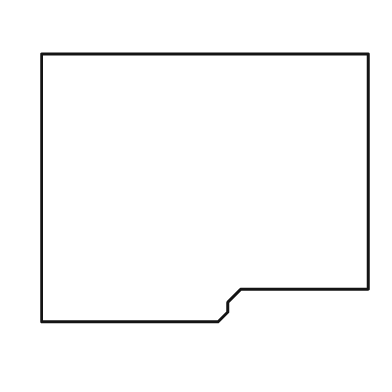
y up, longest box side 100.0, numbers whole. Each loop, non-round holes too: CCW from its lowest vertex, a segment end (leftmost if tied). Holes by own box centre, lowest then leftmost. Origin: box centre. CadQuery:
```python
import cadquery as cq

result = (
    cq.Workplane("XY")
    .moveTo(-50.0, -41.0)
    .lineTo(4.0, -41.0)
    .lineTo(7.0, -38.0)
    .lineTo(7.0, -35.0)
    .lineTo(11.0, -31.0)
    .lineTo(50.0, -31.0)
    .lineTo(50.0, 41.0)
    .lineTo(-50.0, 41.0)
    .close()
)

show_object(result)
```